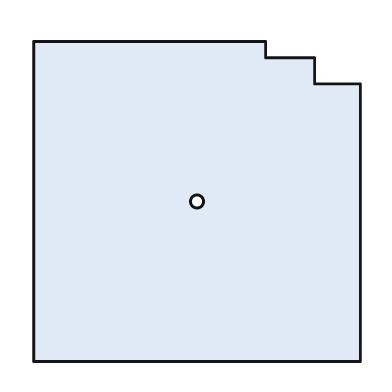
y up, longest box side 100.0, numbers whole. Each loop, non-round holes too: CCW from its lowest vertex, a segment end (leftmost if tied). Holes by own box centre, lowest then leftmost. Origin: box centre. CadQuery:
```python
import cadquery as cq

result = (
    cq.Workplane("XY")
    .moveTo(-50.0, -49.0)
    .lineTo(50.0, -49.0)
    .lineTo(50.0, 36.0)
    .lineTo(36.0, 36.0)
    .lineTo(36.0, 44.0)
    .lineTo(21.0, 44.0)
    .lineTo(21.0, 49.0)
    .lineTo(-50.0, 49.0)
    .close()
    .moveTo(0.0, 0.0)
    .circle(2.0)
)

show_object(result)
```